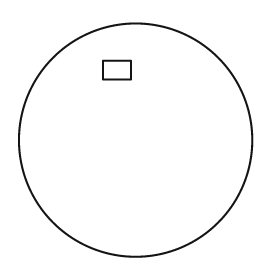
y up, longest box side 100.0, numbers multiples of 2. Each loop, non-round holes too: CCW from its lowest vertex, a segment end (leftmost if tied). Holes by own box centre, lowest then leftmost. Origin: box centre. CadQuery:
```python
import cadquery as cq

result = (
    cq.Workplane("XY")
    .moveTo(0.0, 0.0)
    .circle(50.0)
    .moveTo(-14.0, 26.0)
    .lineTo(-2.0, 26.0)
    .lineTo(-2.0, 34.0)
    .lineTo(-14.0, 34.0)
    .close()
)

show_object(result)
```